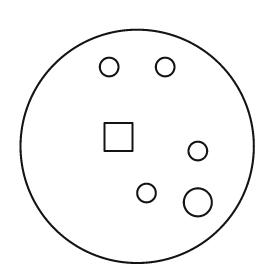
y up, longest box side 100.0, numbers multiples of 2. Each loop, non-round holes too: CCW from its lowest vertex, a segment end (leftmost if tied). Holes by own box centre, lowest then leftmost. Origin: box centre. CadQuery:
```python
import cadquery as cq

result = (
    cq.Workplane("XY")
    .moveTo(0.0, 0.0)
    .circle(50.0)
    .moveTo(26.0, -24.0)
    .circle(6.0)
    .moveTo(4.0, -20.0)
    .circle(4.0)
    .moveTo(26.0, -2.0)
    .circle(4.0)
    .moveTo(-14.0, -2.0)
    .lineTo(-2.0, -2.0)
    .lineTo(-2.0, 10.0)
    .lineTo(-14.0, 10.0)
    .close()
    .moveTo(-12.0, 34.0)
    .circle(4.0)
    .moveTo(12.0, 34.0)
    .circle(4.0)
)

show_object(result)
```